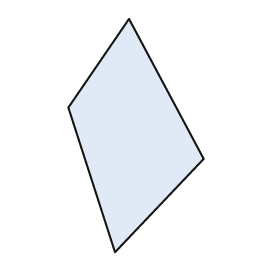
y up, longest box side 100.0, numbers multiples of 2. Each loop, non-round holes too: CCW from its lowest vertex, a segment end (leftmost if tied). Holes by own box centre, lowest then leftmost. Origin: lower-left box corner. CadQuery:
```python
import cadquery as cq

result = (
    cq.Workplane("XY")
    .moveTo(20.0, 0.0)
    .lineTo(58.0, 40.0)
    .lineTo(26.0, 100.0)
    .lineTo(0.0, 62.0)
    .close()
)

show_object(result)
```